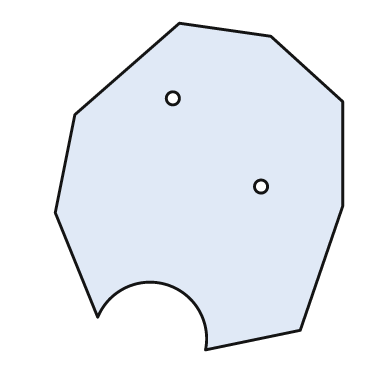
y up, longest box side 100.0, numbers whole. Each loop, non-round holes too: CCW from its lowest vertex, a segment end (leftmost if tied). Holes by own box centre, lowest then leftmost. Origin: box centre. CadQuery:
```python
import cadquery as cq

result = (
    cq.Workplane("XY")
    .moveTo(2.0, -50.0)
    .lineTo(31.0, -44.0)
    .lineTo(44.0, -6.0)
    .lineTo(44.0, 26.0)
    .lineTo(22.0, 46.0)
    .lineTo(-6.0, 50.0)
    .lineTo(-38.0, 22.0)
    .lineTo(-44.0, -8.0)
    .lineTo(-31.0, -40.0)
    .threePointArc((-10.0, -30.0), (2.0, -50.0))
    .close()
    .moveTo(19.0, 0.0)
    .circle(2.0)
    .moveTo(-8.0, 27.0)
    .circle(2.0)
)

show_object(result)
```